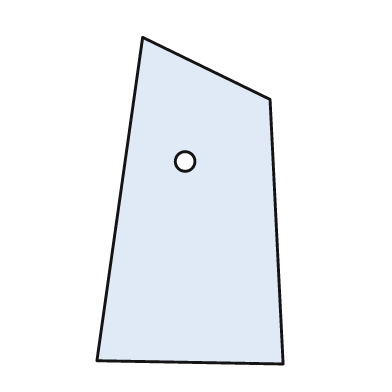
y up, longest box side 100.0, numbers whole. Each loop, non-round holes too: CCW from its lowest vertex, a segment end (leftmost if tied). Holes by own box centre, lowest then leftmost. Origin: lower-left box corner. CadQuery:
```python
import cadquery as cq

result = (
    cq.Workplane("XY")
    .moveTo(57.0, 0.0)
    .lineTo(53.0, 81.0)
    .lineTo(14.0, 100.0)
    .lineTo(0.0, 1.0)
    .close()
    .moveTo(27.0, 62.0)
    .circle(3.0)
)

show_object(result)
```